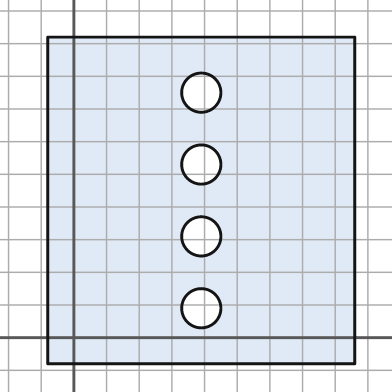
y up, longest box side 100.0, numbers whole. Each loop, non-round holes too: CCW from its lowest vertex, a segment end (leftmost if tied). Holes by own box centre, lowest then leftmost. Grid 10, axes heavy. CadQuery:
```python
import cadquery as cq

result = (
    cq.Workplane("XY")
    .moveTo(-8.0, -8.0)
    .lineTo(86.0, -8.0)
    .lineTo(86.0, 92.0)
    .lineTo(-8.0, 92.0)
    .close()
    .moveTo(39.0, 9.0)
    .circle(6.0)
    .moveTo(39.0, 31.0)
    .circle(6.0)
    .moveTo(39.0, 53.0)
    .circle(6.0)
    .moveTo(39.0, 75.0)
    .circle(6.0)
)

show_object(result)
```